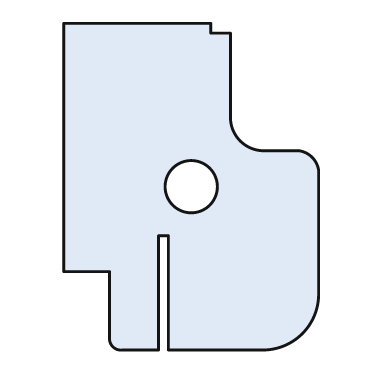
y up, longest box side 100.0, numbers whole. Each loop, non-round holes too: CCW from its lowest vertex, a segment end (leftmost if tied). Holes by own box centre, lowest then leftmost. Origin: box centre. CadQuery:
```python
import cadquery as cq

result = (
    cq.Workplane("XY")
    .moveTo(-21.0, -50.0)
    .lineTo(-10.0, -50.0)
    .lineTo(-10.0, -15.0)
    .lineTo(-7.0, -15.0)
    .lineTo(-7.0, -50.0)
    .lineTo(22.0, -50.0)
    .threePointArc((34.0, -45.0), (39.0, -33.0))
    .lineTo(39.0, 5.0)
    .threePointArc((37.0, 9.0), (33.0, 11.0))
    .lineTo(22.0, 11.0)
    .threePointArc((15.0, 14.0), (12.0, 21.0))
    .lineTo(12.0, 47.0)
    .lineTo(6.0, 47.0)
    .lineTo(6.0, 50.0)
    .lineTo(-39.0, 50.0)
    .lineTo(-39.0, -26.0)
    .lineTo(-25.0, -26.0)
    .lineTo(-25.0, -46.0)
    .threePointArc((-24.0, -49.0), (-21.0, -50.0))
    .close()
    .moveTo(0.0, 0.0)
    .circle(8.0)
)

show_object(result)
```